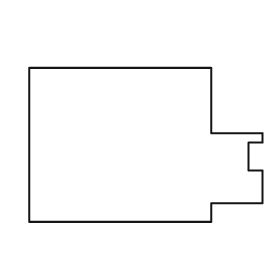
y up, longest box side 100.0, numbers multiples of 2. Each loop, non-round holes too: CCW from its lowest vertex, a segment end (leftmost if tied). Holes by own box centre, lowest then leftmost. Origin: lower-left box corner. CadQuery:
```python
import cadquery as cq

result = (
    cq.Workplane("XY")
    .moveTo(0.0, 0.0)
    .lineTo(78.0, 0.0)
    .lineTo(78.0, 8.0)
    .lineTo(100.0, 8.0)
    .lineTo(100.0, 22.0)
    .lineTo(94.0, 22.0)
    .lineTo(94.0, 34.0)
    .lineTo(100.0, 34.0)
    .lineTo(100.0, 38.0)
    .lineTo(78.0, 38.0)
    .lineTo(78.0, 66.0)
    .lineTo(0.0, 66.0)
    .close()
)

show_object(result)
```